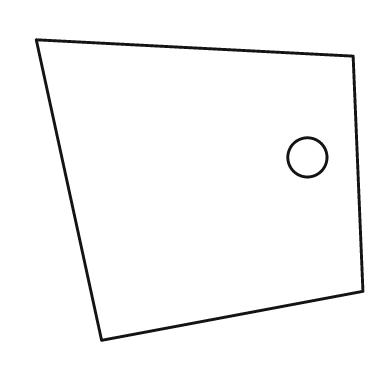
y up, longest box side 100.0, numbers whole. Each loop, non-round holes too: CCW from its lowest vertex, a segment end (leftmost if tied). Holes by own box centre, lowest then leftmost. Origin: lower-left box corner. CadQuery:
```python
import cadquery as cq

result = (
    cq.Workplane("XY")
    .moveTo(20.0, 0.0)
    .lineTo(100.0, 15.0)
    .lineTo(97.0, 87.0)
    .lineTo(0.0, 92.0)
    .close()
    .moveTo(83.0, 56.0)
    .circle(6.0)
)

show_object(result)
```